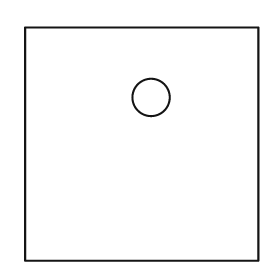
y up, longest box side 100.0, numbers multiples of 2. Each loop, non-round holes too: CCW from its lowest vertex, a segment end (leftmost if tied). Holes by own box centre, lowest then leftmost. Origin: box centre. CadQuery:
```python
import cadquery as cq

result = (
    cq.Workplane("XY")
    .moveTo(-50.0, -50.0)
    .lineTo(50.0, -50.0)
    .lineTo(50.0, 50.0)
    .lineTo(-50.0, 50.0)
    .close()
    .moveTo(4.0, 20.0)
    .circle(8.0)
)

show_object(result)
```